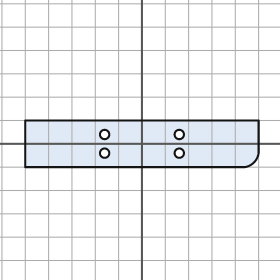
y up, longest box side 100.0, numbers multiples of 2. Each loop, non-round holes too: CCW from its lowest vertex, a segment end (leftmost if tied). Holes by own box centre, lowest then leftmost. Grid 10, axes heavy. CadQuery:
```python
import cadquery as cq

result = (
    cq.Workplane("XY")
    .moveTo(-50.0, -10.0)
    .lineTo(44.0, -10.0)
    .threePointArc((48.0, -8.0), (50.0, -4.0))
    .lineTo(50.0, 10.0)
    .lineTo(-50.0, 10.0)
    .close()
    .moveTo(-16.0, -4.0)
    .circle(2.0)
    .moveTo(16.0, -4.0)
    .circle(2.0)
    .moveTo(-16.0, 4.0)
    .circle(2.0)
    .moveTo(16.0, 4.0)
    .circle(2.0)
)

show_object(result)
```